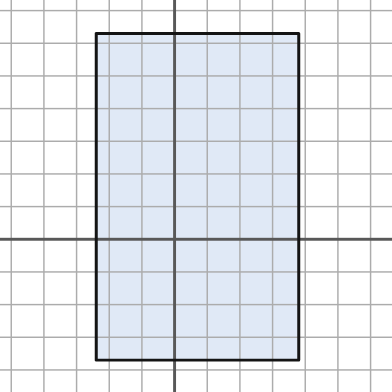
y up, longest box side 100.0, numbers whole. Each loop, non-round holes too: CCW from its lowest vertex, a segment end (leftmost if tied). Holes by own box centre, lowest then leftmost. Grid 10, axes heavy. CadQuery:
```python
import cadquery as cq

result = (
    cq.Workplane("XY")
    .moveTo(-24.0, -37.0)
    .lineTo(38.0, -37.0)
    .lineTo(38.0, 63.0)
    .lineTo(-24.0, 63.0)
    .close()
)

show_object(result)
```